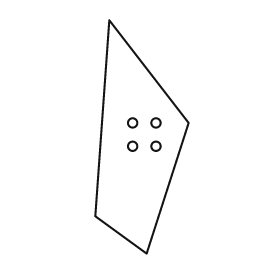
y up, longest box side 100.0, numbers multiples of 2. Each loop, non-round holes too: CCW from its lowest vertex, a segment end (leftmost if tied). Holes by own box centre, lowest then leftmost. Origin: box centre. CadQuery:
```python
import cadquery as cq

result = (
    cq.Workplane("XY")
    .moveTo(2.0, -50.0)
    .lineTo(20.0, 6.0)
    .lineTo(-14.0, 50.0)
    .lineTo(-20.0, -34.0)
    .close()
    .moveTo(-4.0, -4.0)
    .circle(2.0)
    .moveTo(6.0, -4.0)
    .circle(2.0)
    .moveTo(-4.0, 6.0)
    .circle(2.0)
    .moveTo(6.0, 6.0)
    .circle(2.0)
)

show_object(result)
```